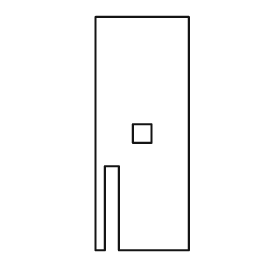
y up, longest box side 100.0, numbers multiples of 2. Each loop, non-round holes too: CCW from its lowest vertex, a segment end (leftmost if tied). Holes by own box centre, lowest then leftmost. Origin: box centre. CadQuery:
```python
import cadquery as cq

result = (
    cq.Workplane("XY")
    .moveTo(-20.0, -50.0)
    .lineTo(-16.0, -50.0)
    .lineTo(-16.0, -14.0)
    .lineTo(-10.0, -14.0)
    .lineTo(-10.0, -50.0)
    .lineTo(20.0, -50.0)
    .lineTo(20.0, 50.0)
    .lineTo(-20.0, 50.0)
    .close()
    .moveTo(-4.0, -4.0)
    .lineTo(4.0, -4.0)
    .lineTo(4.0, 4.0)
    .lineTo(-4.0, 4.0)
    .close()
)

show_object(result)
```